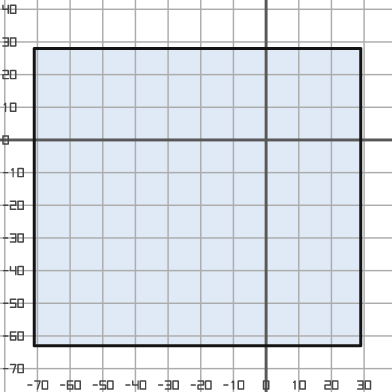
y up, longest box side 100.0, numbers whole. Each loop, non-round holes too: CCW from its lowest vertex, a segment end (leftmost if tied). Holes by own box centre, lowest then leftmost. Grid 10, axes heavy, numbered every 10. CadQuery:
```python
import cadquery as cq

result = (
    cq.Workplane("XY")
    .moveTo(-71.0, -63.0)
    .lineTo(29.0, -63.0)
    .lineTo(29.0, 28.0)
    .lineTo(-71.0, 28.0)
    .close()
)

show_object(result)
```